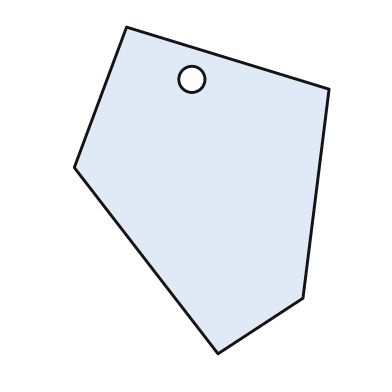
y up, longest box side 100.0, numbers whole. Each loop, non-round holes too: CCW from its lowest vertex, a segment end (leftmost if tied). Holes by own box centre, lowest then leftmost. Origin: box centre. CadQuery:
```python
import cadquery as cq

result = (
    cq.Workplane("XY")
    .moveTo(5.0, -50.0)
    .lineTo(31.0, -33.0)
    .lineTo(39.0, 31.0)
    .lineTo(-23.0, 50.0)
    .lineTo(-39.0, 7.0)
    .close()
    .moveTo(-3.0, 34.0)
    .circle(4.0)
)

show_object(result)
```